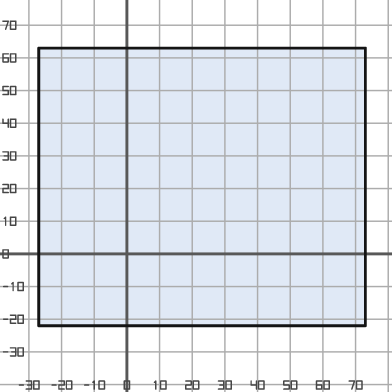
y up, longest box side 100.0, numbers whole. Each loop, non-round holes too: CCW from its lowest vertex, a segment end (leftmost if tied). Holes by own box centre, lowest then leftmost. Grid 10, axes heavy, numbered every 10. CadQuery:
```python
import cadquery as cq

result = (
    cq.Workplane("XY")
    .moveTo(-27.0, -22.0)
    .lineTo(73.0, -22.0)
    .lineTo(73.0, 63.0)
    .lineTo(-27.0, 63.0)
    .close()
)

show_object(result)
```